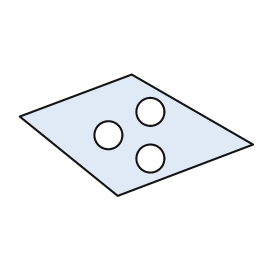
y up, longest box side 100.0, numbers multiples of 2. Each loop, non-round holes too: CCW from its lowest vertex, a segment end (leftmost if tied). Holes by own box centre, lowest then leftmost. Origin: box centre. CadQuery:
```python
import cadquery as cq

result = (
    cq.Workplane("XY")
    .moveTo(-8.0, -26.0)
    .lineTo(50.0, -4.0)
    .lineTo(-2.0, 26.0)
    .lineTo(-50.0, 8.0)
    .close()
    .moveTo(6.0, -10.0)
    .circle(6.0)
    .moveTo(-12.0, 0.0)
    .circle(6.0)
    .moveTo(6.0, 10.0)
    .circle(6.0)
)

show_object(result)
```